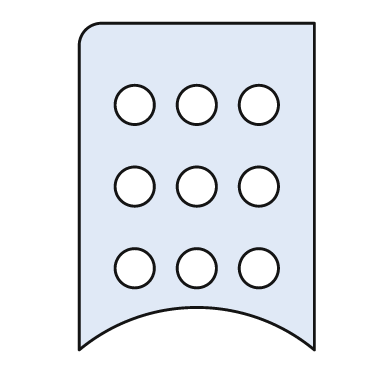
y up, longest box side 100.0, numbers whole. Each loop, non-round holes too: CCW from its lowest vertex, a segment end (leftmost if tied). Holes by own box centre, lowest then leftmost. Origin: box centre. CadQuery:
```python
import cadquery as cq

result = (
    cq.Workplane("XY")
    .moveTo(-36.0, -50.0)
    .threePointArc((0.0, -37.0), (36.0, -50.0))
    .lineTo(36.0, 50.0)
    .lineTo(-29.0, 50.0)
    .threePointArc((-34.0, 48.0), (-36.0, 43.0))
    .close()
    .moveTo(-19.0, -25.0)
    .circle(6.0)
    .moveTo(0.0, -25.0)
    .circle(6.0)
    .moveTo(19.0, -25.0)
    .circle(6.0)
    .moveTo(-19.0, 0.0)
    .circle(6.0)
    .moveTo(0.0, 0.0)
    .circle(6.0)
    .moveTo(19.0, 0.0)
    .circle(6.0)
    .moveTo(-19.0, 25.0)
    .circle(6.0)
    .moveTo(0.0, 25.0)
    .circle(6.0)
    .moveTo(19.0, 25.0)
    .circle(6.0)
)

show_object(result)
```